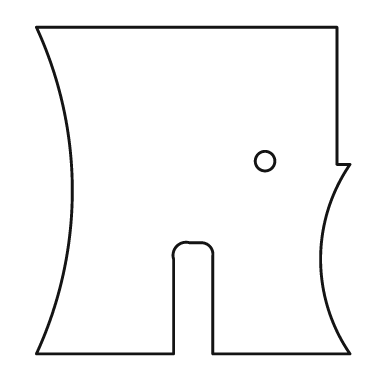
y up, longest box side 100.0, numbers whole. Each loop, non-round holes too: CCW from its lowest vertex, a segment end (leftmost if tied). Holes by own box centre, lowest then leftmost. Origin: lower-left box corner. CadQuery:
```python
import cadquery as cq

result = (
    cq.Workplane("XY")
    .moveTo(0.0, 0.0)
    .lineTo(42.0, 0.0)
    .lineTo(42.0, 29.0)
    .threePointArc((43.0, 33.0), (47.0, 34.0))
    .lineTo(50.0, 34.0)
    .threePointArc((53.0, 33.0), (54.0, 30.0))
    .lineTo(54.0, 0.0)
    .lineTo(96.0, 0.0)
    .threePointArc((87.0, 29.0), (96.0, 58.0))
    .lineTo(92.0, 58.0)
    .lineTo(92.0, 100.0)
    .lineTo(0.0, 100.0)
    .threePointArc((11.0, 50.0), (0.0, 0.0))
    .close()
    .moveTo(70.0, 59.0)
    .circle(3.0)
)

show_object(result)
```